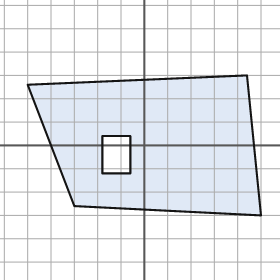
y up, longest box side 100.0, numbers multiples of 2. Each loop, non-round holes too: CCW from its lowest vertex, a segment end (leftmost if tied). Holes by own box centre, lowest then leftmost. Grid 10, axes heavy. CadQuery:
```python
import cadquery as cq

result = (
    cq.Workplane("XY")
    .moveTo(50.0, -30.0)
    .lineTo(44.0, 30.0)
    .lineTo(-50.0, 26.0)
    .lineTo(-30.0, -26.0)
    .close()
    .moveTo(-18.0, -12.0)
    .lineTo(-6.0, -12.0)
    .lineTo(-6.0, 4.0)
    .lineTo(-18.0, 4.0)
    .close()
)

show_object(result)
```